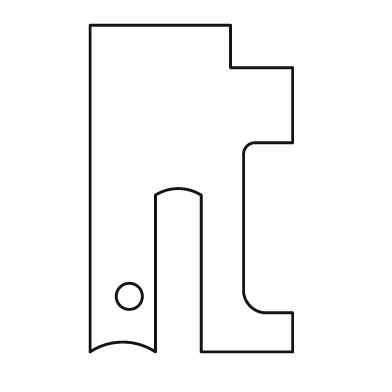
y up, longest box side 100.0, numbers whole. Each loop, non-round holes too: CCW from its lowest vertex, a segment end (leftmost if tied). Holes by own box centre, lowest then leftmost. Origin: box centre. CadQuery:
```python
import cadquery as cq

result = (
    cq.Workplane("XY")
    .moveTo(-31.0, -50.0)
    .threePointArc((-21.0, -47.0), (-11.0, -50.0))
    .lineTo(-11.0, -2.0)
    .threePointArc((-4.0, 0.0), (3.0, -2.0))
    .lineTo(3.0, -50.0)
    .lineTo(31.0, -50.0)
    .lineTo(31.0, -38.0)
    .lineTo(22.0, -38.0)
    .threePointArc((18.0, -36.0), (16.0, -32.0))
    .lineTo(16.0, 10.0)
    .threePointArc((17.0, 13.0), (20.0, 14.0))
    .lineTo(31.0, 14.0)
    .lineTo(31.0, 37.0)
    .lineTo(12.0, 37.0)
    .lineTo(12.0, 50.0)
    .lineTo(-31.0, 50.0)
    .close()
    .moveTo(-19.0, -33.0)
    .circle(4.0)
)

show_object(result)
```